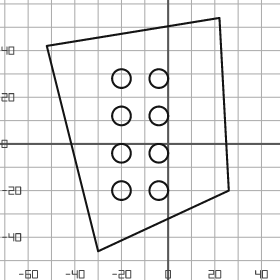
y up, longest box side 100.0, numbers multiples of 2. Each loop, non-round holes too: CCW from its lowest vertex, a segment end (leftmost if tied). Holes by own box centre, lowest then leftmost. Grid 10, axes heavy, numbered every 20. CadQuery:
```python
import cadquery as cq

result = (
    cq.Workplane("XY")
    .moveTo(-30.0, -46.0)
    .lineTo(26.0, -20.0)
    .lineTo(22.0, 54.0)
    .lineTo(-52.0, 42.0)
    .close()
    .moveTo(-20.0, -20.0)
    .circle(4.0)
    .moveTo(-4.0, -20.0)
    .circle(4.0)
    .moveTo(-20.0, -4.0)
    .circle(4.0)
    .moveTo(-4.0, -4.0)
    .circle(4.0)
    .moveTo(-20.0, 12.0)
    .circle(4.0)
    .moveTo(-4.0, 12.0)
    .circle(4.0)
    .moveTo(-20.0, 28.0)
    .circle(4.0)
    .moveTo(-4.0, 28.0)
    .circle(4.0)
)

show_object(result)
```